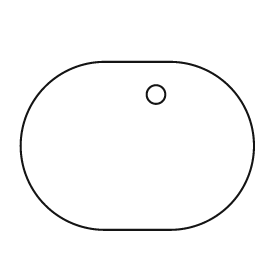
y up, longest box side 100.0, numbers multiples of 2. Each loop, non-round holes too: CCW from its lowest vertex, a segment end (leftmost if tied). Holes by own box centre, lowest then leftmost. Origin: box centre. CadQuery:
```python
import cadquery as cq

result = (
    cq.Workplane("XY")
    .moveTo(-14.0, -36.0)
    .lineTo(14.0, -36.0)
    .threePointArc((50.0, 0.0), (14.0, 36.0))
    .lineTo(-14.0, 36.0)
    .threePointArc((-50.0, 0.0), (-14.0, -36.0))
    .close()
    .moveTo(8.0, 22.0)
    .circle(4.0)
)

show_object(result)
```